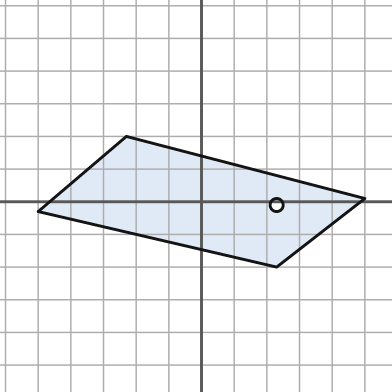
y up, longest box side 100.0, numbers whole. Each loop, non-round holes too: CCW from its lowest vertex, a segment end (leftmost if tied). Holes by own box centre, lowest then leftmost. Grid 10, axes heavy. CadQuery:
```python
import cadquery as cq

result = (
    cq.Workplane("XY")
    .moveTo(23.0, -20.0)
    .lineTo(50.0, 1.0)
    .lineTo(-23.0, 20.0)
    .lineTo(-50.0, -3.0)
    .close()
    .moveTo(23.0, -1.0)
    .circle(2.0)
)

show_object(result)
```